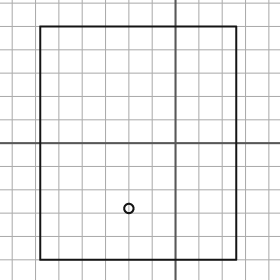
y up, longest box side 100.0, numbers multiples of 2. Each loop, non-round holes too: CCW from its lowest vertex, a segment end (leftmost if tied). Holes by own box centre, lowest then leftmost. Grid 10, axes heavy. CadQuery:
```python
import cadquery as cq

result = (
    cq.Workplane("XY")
    .moveTo(-58.0, -50.0)
    .lineTo(26.0, -50.0)
    .lineTo(26.0, 50.0)
    .lineTo(-58.0, 50.0)
    .close()
    .moveTo(-20.0, -28.0)
    .circle(2.0)
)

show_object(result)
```